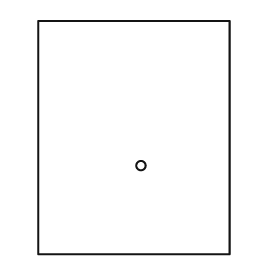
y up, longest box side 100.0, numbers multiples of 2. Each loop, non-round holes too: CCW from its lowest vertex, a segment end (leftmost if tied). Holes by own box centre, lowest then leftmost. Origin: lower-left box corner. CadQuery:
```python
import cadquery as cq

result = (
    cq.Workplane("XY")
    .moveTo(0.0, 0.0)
    .lineTo(82.0, 0.0)
    .lineTo(82.0, 100.0)
    .lineTo(0.0, 100.0)
    .close()
    .moveTo(44.0, 38.0)
    .circle(2.0)
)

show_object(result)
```